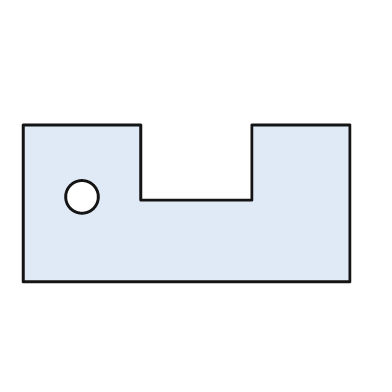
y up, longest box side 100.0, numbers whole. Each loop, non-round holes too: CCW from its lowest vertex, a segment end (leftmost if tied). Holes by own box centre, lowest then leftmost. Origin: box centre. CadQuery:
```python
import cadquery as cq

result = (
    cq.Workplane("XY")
    .moveTo(-50.0, -24.0)
    .lineTo(50.0, -24.0)
    .lineTo(50.0, 24.0)
    .lineTo(20.0, 24.0)
    .lineTo(20.0, 1.0)
    .lineTo(-14.0, 1.0)
    .lineTo(-14.0, 24.0)
    .lineTo(-50.0, 24.0)
    .close()
    .moveTo(-32.0, 2.0)
    .circle(5.0)
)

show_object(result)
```